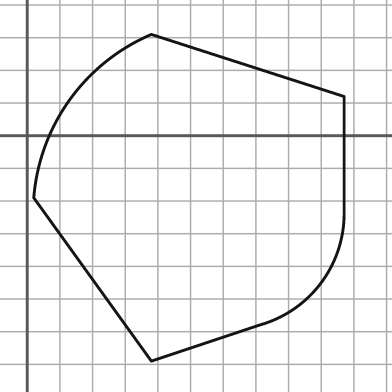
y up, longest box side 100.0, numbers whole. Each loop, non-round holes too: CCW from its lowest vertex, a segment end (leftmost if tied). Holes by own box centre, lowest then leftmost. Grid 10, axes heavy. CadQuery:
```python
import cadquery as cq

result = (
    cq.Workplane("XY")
    .moveTo(38.0, -69.0)
    .lineTo(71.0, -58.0)
    .threePointArc((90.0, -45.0), (97.0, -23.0))
    .lineTo(97.0, 12.0)
    .lineTo(38.0, 31.0)
    .threePointArc((13.0, 11.0), (2.0, -19.0))
    .close()
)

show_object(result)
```